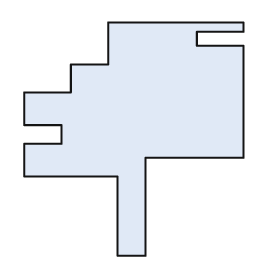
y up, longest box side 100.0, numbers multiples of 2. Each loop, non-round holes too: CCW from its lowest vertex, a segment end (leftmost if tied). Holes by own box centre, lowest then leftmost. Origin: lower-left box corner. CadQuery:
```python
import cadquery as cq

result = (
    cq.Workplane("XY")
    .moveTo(40.0, 0.0)
    .lineTo(52.0, 0.0)
    .lineTo(52.0, 42.0)
    .lineTo(94.0, 42.0)
    .lineTo(94.0, 90.0)
    .lineTo(74.0, 90.0)
    .lineTo(74.0, 96.0)
    .lineTo(94.0, 96.0)
    .lineTo(94.0, 100.0)
    .lineTo(36.0, 100.0)
    .lineTo(36.0, 82.0)
    .lineTo(20.0, 82.0)
    .lineTo(20.0, 70.0)
    .lineTo(0.0, 70.0)
    .lineTo(0.0, 56.0)
    .lineTo(16.0, 56.0)
    .lineTo(16.0, 48.0)
    .lineTo(0.0, 48.0)
    .lineTo(0.0, 34.0)
    .lineTo(40.0, 34.0)
    .close()
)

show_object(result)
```